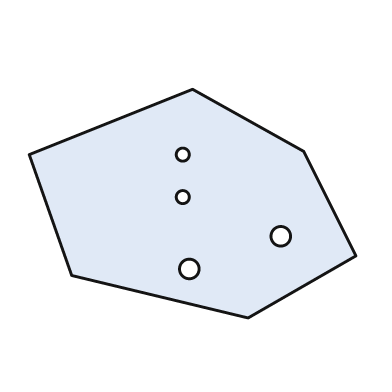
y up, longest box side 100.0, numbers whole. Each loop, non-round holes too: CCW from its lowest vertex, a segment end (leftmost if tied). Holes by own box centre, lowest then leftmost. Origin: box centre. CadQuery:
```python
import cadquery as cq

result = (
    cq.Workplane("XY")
    .moveTo(17.0, -35.0)
    .lineTo(50.0, -16.0)
    .lineTo(34.0, 16.0)
    .lineTo(0.0, 35.0)
    .lineTo(-50.0, 15.0)
    .lineTo(-37.0, -22.0)
    .close()
    .moveTo(-1.0, -20.0)
    .circle(3.0)
    .moveTo(27.0, -10.0)
    .circle(3.0)
    .moveTo(-3.0, 2.0)
    .circle(2.0)
    .moveTo(-3.0, 15.0)
    .circle(2.0)
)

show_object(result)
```